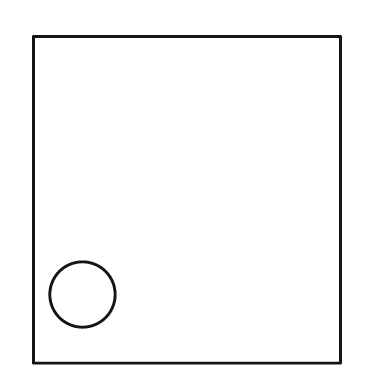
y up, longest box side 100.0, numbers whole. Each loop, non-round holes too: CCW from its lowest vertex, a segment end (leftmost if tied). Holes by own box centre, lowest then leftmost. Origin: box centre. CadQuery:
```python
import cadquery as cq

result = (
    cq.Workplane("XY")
    .moveTo(-47.0, -50.0)
    .lineTo(47.0, -50.0)
    .lineTo(47.0, 50.0)
    .lineTo(-47.0, 50.0)
    .close()
    .moveTo(-32.0, -29.0)
    .circle(10.0)
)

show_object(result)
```